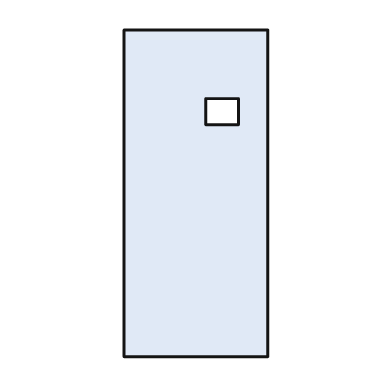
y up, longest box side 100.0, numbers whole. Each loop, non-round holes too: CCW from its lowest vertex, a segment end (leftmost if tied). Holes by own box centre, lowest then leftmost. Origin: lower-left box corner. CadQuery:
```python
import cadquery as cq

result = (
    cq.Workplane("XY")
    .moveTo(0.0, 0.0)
    .lineTo(44.0, 0.0)
    .lineTo(44.0, 100.0)
    .lineTo(0.0, 100.0)
    .close()
    .moveTo(25.0, 71.0)
    .lineTo(35.0, 71.0)
    .lineTo(35.0, 79.0)
    .lineTo(25.0, 79.0)
    .close()
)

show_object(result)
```